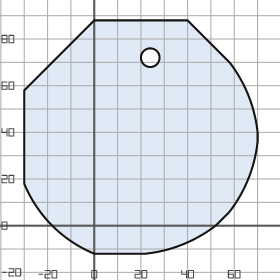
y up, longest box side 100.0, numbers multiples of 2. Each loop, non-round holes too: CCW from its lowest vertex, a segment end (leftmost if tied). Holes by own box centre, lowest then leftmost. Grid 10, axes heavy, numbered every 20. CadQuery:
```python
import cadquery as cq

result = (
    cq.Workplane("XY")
    .moveTo(0.0, -12.0)
    .lineTo(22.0, -12.0)
    .threePointArc((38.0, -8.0), (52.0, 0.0))
    .lineTo(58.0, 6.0)
    .threePointArc((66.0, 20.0), (70.0, 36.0))
    .lineTo(70.0, 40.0)
    .threePointArc((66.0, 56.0), (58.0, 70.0))
    .lineTo(40.0, 88.0)
    .lineTo(0.0, 88.0)
    .lineTo(-30.0, 58.0)
    .lineTo(-30.0, 18.0)
    .threePointArc((-18.0, 0.0), (0.0, -12.0))
    .close()
    .moveTo(24.0, 72.0)
    .circle(4.0)
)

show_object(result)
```